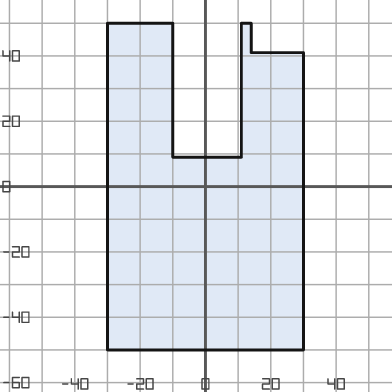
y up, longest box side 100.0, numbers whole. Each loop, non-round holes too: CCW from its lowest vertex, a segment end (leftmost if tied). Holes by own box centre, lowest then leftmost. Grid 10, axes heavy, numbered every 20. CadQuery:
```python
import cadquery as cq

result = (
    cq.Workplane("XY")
    .moveTo(-30.0, -50.0)
    .lineTo(30.0, -50.0)
    .lineTo(30.0, 41.0)
    .lineTo(14.0, 41.0)
    .lineTo(14.0, 50.0)
    .lineTo(11.0, 50.0)
    .lineTo(11.0, 9.0)
    .lineTo(-10.0, 9.0)
    .lineTo(-10.0, 50.0)
    .lineTo(-30.0, 50.0)
    .close()
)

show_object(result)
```